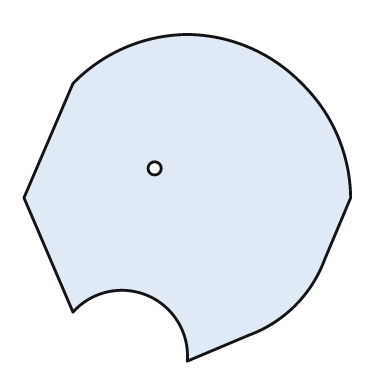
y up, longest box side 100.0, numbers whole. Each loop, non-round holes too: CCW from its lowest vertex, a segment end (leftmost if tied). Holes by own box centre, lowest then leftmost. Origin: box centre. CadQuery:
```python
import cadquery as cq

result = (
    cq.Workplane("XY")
    .moveTo(0.0, -50.0)
    .lineTo(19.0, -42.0)
    .threePointArc((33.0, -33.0), (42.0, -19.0))
    .lineTo(50.0, 0.0)
    .threePointArc((46.0, 19.0), (35.0, 35.0))
    .threePointArc((19.0, 46.0), (0.0, 50.0))
    .threePointArc((-19.0, 46.0), (-35.0, 35.0))
    .lineTo(-50.0, 0.0)
    .lineTo(-35.0, -35.0)
    .threePointArc((-12.0, -30.0), (0.0, -50.0))
    .close()
    .moveTo(-10.0, 9.0)
    .circle(2.0)
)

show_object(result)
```